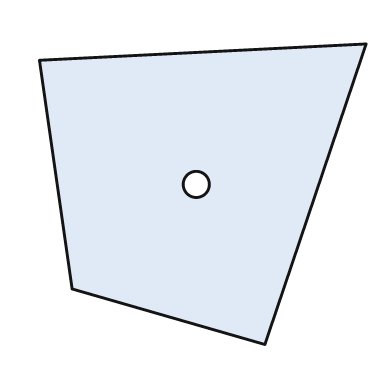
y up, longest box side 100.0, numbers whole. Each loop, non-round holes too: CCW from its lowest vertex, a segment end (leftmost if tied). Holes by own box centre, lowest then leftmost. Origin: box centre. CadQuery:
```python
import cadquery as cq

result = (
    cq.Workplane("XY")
    .moveTo(19.0, -46.0)
    .lineTo(50.0, 46.0)
    .lineTo(-50.0, 41.0)
    .lineTo(-40.0, -29.0)
    .close()
    .moveTo(-2.0, 3.0)
    .circle(4.0)
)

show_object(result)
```